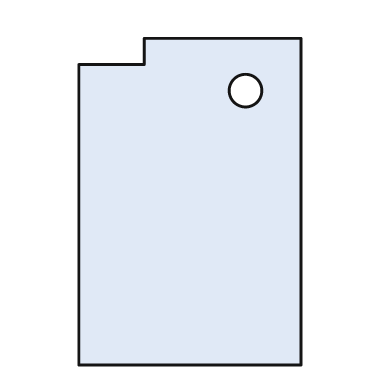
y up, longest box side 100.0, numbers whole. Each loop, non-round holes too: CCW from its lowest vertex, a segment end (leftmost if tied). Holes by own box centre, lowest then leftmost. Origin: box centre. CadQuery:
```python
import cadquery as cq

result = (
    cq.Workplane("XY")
    .moveTo(-34.0, -50.0)
    .lineTo(34.0, -50.0)
    .lineTo(34.0, 50.0)
    .lineTo(-14.0, 50.0)
    .lineTo(-14.0, 42.0)
    .lineTo(-34.0, 42.0)
    .close()
    .moveTo(17.0, 34.0)
    .circle(5.0)
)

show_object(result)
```